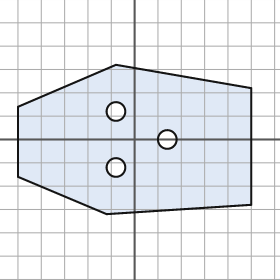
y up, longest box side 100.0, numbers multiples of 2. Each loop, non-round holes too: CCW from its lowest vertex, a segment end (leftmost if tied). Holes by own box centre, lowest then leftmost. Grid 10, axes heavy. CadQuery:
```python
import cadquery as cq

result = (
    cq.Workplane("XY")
    .moveTo(-12.0, -32.0)
    .lineTo(50.0, -28.0)
    .lineTo(50.0, 22.0)
    .lineTo(-8.0, 32.0)
    .lineTo(-50.0, 14.0)
    .lineTo(-50.0, -16.0)
    .close()
    .moveTo(-8.0, -12.0)
    .circle(4.0)
    .moveTo(14.0, 0.0)
    .circle(4.0)
    .moveTo(-8.0, 12.0)
    .circle(4.0)
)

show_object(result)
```